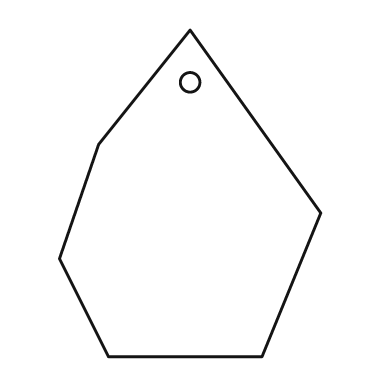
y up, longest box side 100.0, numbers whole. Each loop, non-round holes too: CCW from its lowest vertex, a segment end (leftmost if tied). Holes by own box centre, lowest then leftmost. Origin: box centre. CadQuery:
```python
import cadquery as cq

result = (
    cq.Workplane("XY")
    .moveTo(-25.0, -50.0)
    .lineTo(22.0, -50.0)
    .lineTo(40.0, -6.0)
    .lineTo(0.0, 50.0)
    .lineTo(-28.0, 15.0)
    .lineTo(-40.0, -20.0)
    .close()
    .moveTo(0.0, 34.0)
    .circle(3.0)
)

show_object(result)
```